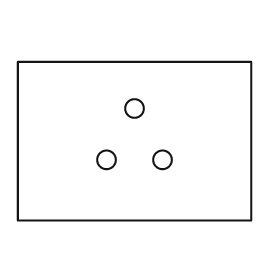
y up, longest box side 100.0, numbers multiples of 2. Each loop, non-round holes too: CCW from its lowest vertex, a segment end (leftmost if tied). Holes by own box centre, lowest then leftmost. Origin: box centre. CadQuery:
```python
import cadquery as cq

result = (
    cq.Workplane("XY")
    .moveTo(-50.0, -34.0)
    .lineTo(50.0, -34.0)
    .lineTo(50.0, 34.0)
    .lineTo(-50.0, 34.0)
    .close()
    .moveTo(-12.0, -8.0)
    .circle(4.0)
    .moveTo(12.0, -8.0)
    .circle(4.0)
    .moveTo(0.0, 14.0)
    .circle(4.0)
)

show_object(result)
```